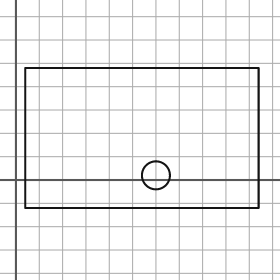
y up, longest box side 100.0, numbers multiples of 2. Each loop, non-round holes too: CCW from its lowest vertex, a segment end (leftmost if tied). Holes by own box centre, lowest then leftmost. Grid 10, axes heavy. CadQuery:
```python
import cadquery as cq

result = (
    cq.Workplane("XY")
    .moveTo(4.0, -12.0)
    .lineTo(104.0, -12.0)
    .lineTo(104.0, 48.0)
    .lineTo(4.0, 48.0)
    .close()
    .moveTo(60.0, 2.0)
    .circle(6.0)
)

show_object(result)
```